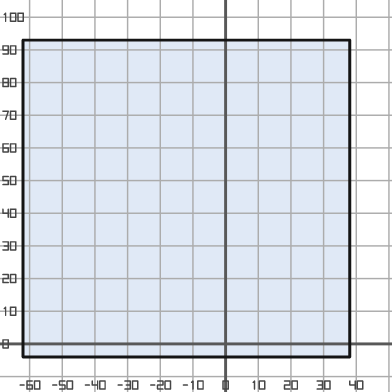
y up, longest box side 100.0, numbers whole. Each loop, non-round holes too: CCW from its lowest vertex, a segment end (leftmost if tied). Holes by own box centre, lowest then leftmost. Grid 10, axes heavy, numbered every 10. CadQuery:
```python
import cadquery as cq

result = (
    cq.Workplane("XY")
    .moveTo(-62.0, -4.0)
    .lineTo(38.0, -4.0)
    .lineTo(38.0, 93.0)
    .lineTo(-62.0, 93.0)
    .close()
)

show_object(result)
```